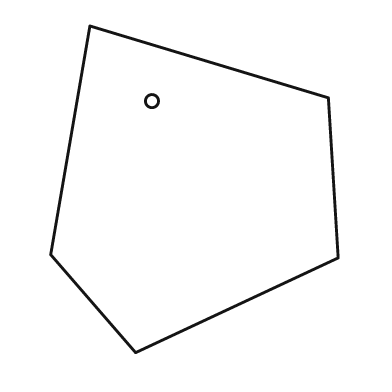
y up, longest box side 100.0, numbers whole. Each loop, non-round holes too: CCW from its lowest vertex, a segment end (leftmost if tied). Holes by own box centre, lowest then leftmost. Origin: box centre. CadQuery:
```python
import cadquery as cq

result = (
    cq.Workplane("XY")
    .moveTo(-18.0, -50.0)
    .lineTo(44.0, -21.0)
    .lineTo(41.0, 28.0)
    .lineTo(-32.0, 50.0)
    .lineTo(-44.0, -20.0)
    .close()
    .moveTo(-13.0, 27.0)
    .circle(2.0)
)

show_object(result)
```